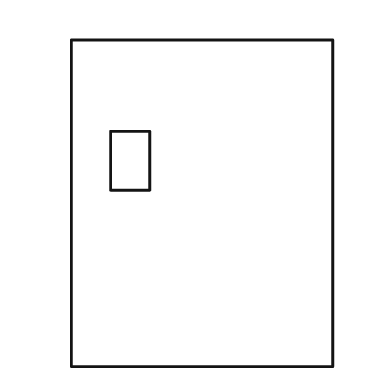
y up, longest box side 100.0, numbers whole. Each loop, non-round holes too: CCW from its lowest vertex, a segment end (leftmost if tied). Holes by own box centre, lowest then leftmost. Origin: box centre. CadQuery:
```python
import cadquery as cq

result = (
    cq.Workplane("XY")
    .moveTo(-40.0, -50.0)
    .lineTo(40.0, -50.0)
    .lineTo(40.0, 50.0)
    .lineTo(-40.0, 50.0)
    .close()
    .moveTo(-28.0, 4.0)
    .lineTo(-16.0, 4.0)
    .lineTo(-16.0, 22.0)
    .lineTo(-28.0, 22.0)
    .close()
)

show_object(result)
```